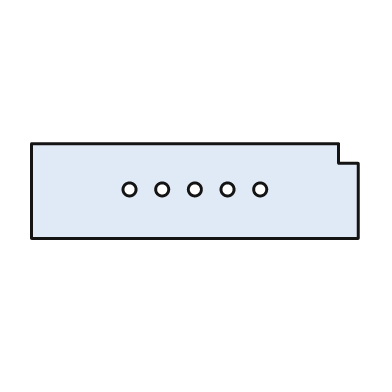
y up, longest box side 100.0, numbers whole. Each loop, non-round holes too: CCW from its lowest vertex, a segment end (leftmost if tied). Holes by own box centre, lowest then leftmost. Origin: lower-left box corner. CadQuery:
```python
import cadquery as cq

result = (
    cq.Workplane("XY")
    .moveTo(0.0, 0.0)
    .lineTo(100.0, 0.0)
    .lineTo(100.0, 23.0)
    .lineTo(94.0, 23.0)
    .lineTo(94.0, 29.0)
    .lineTo(0.0, 29.0)
    .close()
    .moveTo(30.0, 15.0)
    .circle(2.0)
    .moveTo(40.0, 15.0)
    .circle(2.0)
    .moveTo(50.0, 15.0)
    .circle(2.0)
    .moveTo(60.0, 15.0)
    .circle(2.0)
    .moveTo(70.0, 15.0)
    .circle(2.0)
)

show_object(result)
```